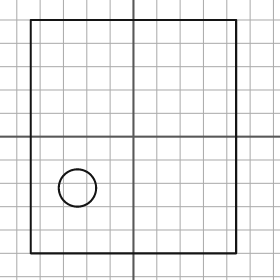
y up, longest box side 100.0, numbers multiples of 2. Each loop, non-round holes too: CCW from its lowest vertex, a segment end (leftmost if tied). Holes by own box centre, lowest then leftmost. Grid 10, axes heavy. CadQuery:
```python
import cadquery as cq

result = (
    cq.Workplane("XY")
    .moveTo(-44.0, -50.0)
    .lineTo(44.0, -50.0)
    .lineTo(44.0, 50.0)
    .lineTo(-44.0, 50.0)
    .close()
    .moveTo(-24.0, -22.0)
    .circle(8.0)
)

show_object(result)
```